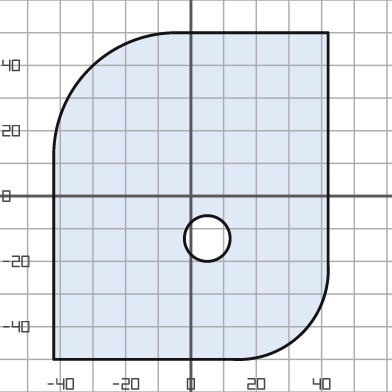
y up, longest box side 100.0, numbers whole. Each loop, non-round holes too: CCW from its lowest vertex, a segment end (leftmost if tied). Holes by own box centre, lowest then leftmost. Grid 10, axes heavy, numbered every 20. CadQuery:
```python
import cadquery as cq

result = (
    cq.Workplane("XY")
    .moveTo(-42.0, -50.0)
    .lineTo(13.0, -50.0)
    .threePointArc((34.0, -42.0), (42.0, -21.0))
    .lineTo(42.0, 50.0)
    .lineTo(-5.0, 50.0)
    .threePointArc((-31.0, 39.0), (-42.0, 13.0))
    .close()
    .moveTo(5.0, -13.0)
    .circle(7.0)
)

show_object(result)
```